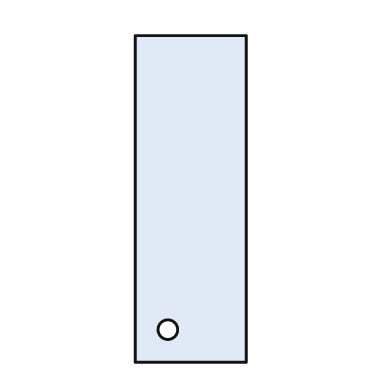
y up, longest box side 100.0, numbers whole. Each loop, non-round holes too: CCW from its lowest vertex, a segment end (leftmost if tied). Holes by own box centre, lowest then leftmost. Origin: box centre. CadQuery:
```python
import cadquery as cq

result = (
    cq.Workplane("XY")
    .moveTo(-17.0, -50.0)
    .lineTo(17.0, -50.0)
    .lineTo(17.0, 50.0)
    .lineTo(-17.0, 50.0)
    .close()
    .moveTo(-7.0, -40.0)
    .circle(3.0)
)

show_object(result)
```